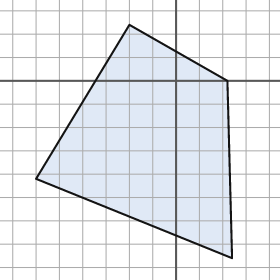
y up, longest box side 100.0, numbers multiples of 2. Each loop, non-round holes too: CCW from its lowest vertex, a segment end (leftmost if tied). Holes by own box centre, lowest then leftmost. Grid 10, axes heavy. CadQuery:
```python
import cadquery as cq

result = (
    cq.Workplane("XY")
    .moveTo(24.0, -76.0)
    .lineTo(22.0, 0.0)
    .lineTo(-20.0, 24.0)
    .lineTo(-60.0, -42.0)
    .close()
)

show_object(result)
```